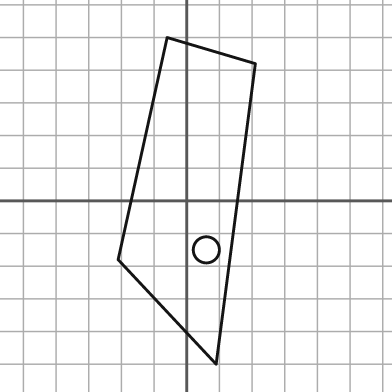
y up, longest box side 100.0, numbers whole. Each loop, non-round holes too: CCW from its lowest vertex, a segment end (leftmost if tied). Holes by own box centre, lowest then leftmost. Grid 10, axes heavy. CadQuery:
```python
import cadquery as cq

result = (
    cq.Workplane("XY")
    .moveTo(9.0, -50.0)
    .lineTo(21.0, 42.0)
    .lineTo(-6.0, 50.0)
    .lineTo(-21.0, -18.0)
    .close()
    .moveTo(6.0, -15.0)
    .circle(4.0)
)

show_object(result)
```